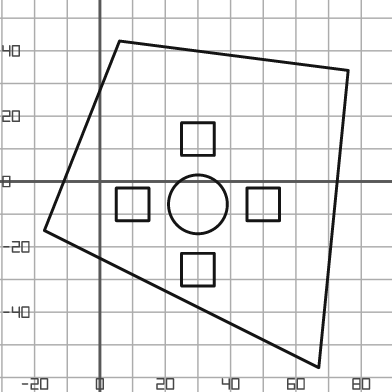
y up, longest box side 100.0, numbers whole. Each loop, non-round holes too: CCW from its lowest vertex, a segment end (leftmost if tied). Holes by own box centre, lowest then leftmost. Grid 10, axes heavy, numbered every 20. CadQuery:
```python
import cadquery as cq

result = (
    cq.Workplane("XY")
    .moveTo(67.0, -57.0)
    .lineTo(76.0, 34.0)
    .lineTo(6.0, 43.0)
    .lineTo(-17.0, -15.0)
    .close()
    .moveTo(25.0, -32.0)
    .lineTo(35.0, -32.0)
    .lineTo(35.0, -22.0)
    .lineTo(25.0, -22.0)
    .close()
    .moveTo(5.0, -12.0)
    .lineTo(15.0, -12.0)
    .lineTo(15.0, -2.0)
    .lineTo(5.0, -2.0)
    .close()
    .moveTo(30.0, -7.0)
    .circle(9.0)
    .moveTo(45.0, -12.0)
    .lineTo(55.0, -12.0)
    .lineTo(55.0, -2.0)
    .lineTo(45.0, -2.0)
    .close()
    .moveTo(25.0, 8.0)
    .lineTo(35.0, 8.0)
    .lineTo(35.0, 18.0)
    .lineTo(25.0, 18.0)
    .close()
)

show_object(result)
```